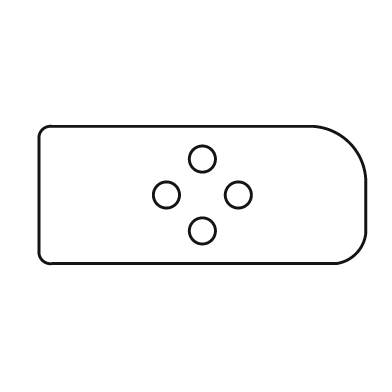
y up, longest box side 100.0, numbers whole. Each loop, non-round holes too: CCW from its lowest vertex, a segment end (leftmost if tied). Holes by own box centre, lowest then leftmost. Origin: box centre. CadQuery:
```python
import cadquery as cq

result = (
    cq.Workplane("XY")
    .moveTo(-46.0, -21.0)
    .lineTo(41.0, -21.0)
    .threePointArc((47.0, -18.0), (50.0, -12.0))
    .lineTo(50.0, 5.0)
    .threePointArc((45.0, 16.0), (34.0, 21.0))
    .lineTo(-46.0, 21.0)
    .threePointArc((-49.0, 20.0), (-50.0, 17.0))
    .lineTo(-50.0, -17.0)
    .threePointArc((-49.0, -20.0), (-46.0, -21.0))
    .close()
    .moveTo(0.0, -11.0)
    .circle(4.0)
    .moveTo(-11.0, 0.0)
    .circle(4.0)
    .moveTo(11.0, 0.0)
    .circle(4.0)
    .moveTo(0.0, 11.0)
    .circle(4.0)
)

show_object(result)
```